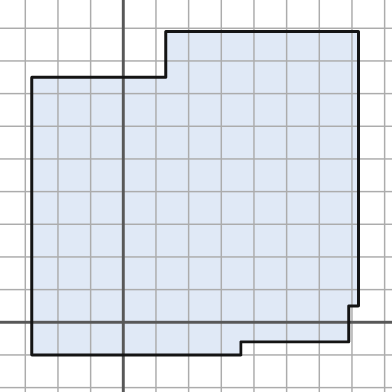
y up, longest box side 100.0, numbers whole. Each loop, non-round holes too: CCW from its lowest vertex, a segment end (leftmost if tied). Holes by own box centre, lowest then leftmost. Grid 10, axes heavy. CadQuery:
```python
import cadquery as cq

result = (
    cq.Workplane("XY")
    .moveTo(-28.0, -10.0)
    .lineTo(36.0, -10.0)
    .lineTo(36.0, -6.0)
    .lineTo(69.0, -6.0)
    .lineTo(69.0, 5.0)
    .lineTo(72.0, 5.0)
    .lineTo(72.0, 89.0)
    .lineTo(13.0, 89.0)
    .lineTo(13.0, 75.0)
    .lineTo(-28.0, 75.0)
    .close()
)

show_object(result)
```